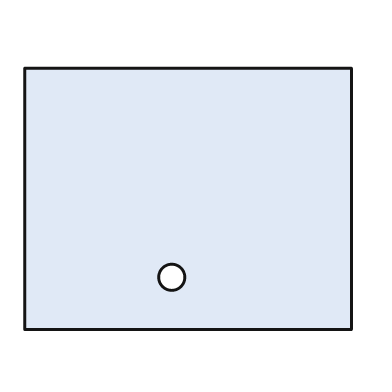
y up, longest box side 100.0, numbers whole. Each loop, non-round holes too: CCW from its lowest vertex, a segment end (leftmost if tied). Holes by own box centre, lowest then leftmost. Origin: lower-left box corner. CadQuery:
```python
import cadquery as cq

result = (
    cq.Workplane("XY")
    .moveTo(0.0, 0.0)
    .lineTo(100.0, 0.0)
    .lineTo(100.0, 80.0)
    .lineTo(0.0, 80.0)
    .close()
    .moveTo(45.0, 16.0)
    .circle(4.0)
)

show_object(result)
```